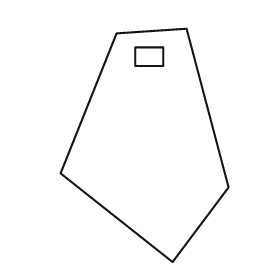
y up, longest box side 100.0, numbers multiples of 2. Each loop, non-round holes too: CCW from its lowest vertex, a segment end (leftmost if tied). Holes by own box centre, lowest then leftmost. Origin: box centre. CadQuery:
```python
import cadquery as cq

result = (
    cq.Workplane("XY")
    .moveTo(12.0, -50.0)
    .lineTo(36.0, -18.0)
    .lineTo(18.0, 50.0)
    .lineTo(-12.0, 48.0)
    .lineTo(-36.0, -12.0)
    .close()
    .moveTo(-4.0, 34.0)
    .lineTo(8.0, 34.0)
    .lineTo(8.0, 42.0)
    .lineTo(-4.0, 42.0)
    .close()
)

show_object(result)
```